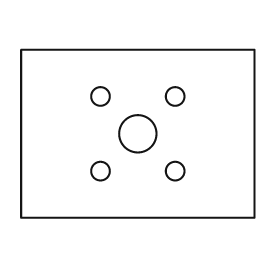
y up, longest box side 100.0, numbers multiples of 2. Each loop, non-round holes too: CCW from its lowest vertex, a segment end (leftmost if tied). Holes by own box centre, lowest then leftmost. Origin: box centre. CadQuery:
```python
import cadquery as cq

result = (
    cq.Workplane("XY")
    .moveTo(-50.0, -36.0)
    .lineTo(50.0, -36.0)
    .lineTo(50.0, 36.0)
    .lineTo(-50.0, 36.0)
    .close()
    .moveTo(-16.0, -16.0)
    .circle(4.0)
    .moveTo(16.0, -16.0)
    .circle(4.0)
    .moveTo(0.0, 0.0)
    .circle(8.0)
    .moveTo(-16.0, 16.0)
    .circle(4.0)
    .moveTo(16.0, 16.0)
    .circle(4.0)
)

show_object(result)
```